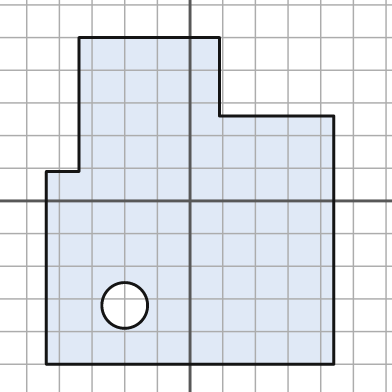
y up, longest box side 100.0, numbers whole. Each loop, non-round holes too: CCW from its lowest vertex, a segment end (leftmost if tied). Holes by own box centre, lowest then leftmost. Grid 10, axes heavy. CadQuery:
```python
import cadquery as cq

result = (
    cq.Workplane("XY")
    .moveTo(-44.0, -50.0)
    .lineTo(44.0, -50.0)
    .lineTo(44.0, 26.0)
    .lineTo(9.0, 26.0)
    .lineTo(9.0, 50.0)
    .lineTo(-34.0, 50.0)
    .lineTo(-34.0, 9.0)
    .lineTo(-44.0, 9.0)
    .close()
    .moveTo(-20.0, -32.0)
    .circle(7.0)
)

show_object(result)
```